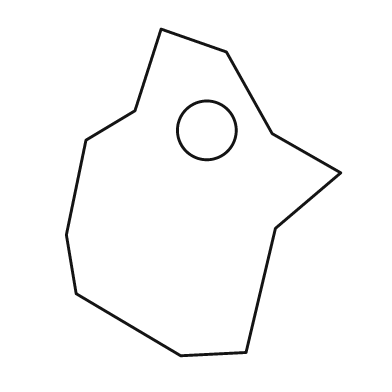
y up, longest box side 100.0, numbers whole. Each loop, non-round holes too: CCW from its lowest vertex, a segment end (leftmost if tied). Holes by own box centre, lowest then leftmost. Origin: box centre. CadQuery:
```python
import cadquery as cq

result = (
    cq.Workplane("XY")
    .moveTo(-7.0, -50.0)
    .lineTo(13.0, -49.0)
    .lineTo(22.0, -11.0)
    .lineTo(42.0, 6.0)
    .lineTo(21.0, 18.0)
    .lineTo(7.0, 43.0)
    .lineTo(-13.0, 50.0)
    .lineTo(-21.0, 25.0)
    .lineTo(-36.0, 16.0)
    .lineTo(-42.0, -13.0)
    .lineTo(-39.0, -31.0)
    .close()
    .moveTo(1.0, 19.0)
    .circle(9.0)
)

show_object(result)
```